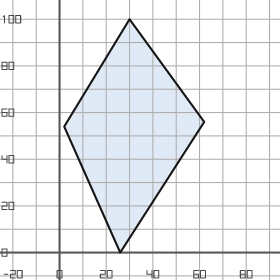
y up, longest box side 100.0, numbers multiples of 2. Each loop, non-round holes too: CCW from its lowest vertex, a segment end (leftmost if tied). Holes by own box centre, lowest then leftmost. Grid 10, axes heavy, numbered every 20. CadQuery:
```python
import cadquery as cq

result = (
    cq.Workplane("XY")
    .moveTo(26.0, 0.0)
    .lineTo(62.0, 56.0)
    .lineTo(30.0, 100.0)
    .lineTo(2.0, 54.0)
    .close()
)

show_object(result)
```